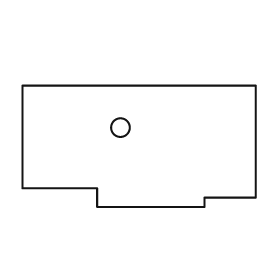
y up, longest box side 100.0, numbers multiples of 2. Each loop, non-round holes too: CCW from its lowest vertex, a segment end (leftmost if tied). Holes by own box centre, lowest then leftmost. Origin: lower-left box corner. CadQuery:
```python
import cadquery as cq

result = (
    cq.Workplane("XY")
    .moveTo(32.0, 0.0)
    .lineTo(78.0, 0.0)
    .lineTo(78.0, 4.0)
    .lineTo(100.0, 4.0)
    .lineTo(100.0, 52.0)
    .lineTo(0.0, 52.0)
    .lineTo(0.0, 8.0)
    .lineTo(32.0, 8.0)
    .close()
    .moveTo(42.0, 34.0)
    .circle(4.0)
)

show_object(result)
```